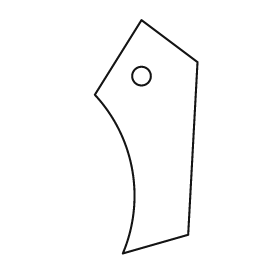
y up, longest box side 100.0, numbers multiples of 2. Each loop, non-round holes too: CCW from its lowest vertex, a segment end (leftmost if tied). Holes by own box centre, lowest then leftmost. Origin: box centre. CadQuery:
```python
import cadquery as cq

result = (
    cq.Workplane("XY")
    .moveTo(-10.0, -50.0)
    .lineTo(18.0, -42.0)
    .lineTo(22.0, 32.0)
    .lineTo(-2.0, 50.0)
    .lineTo(-22.0, 18.0)
    .threePointArc((-6.0, -14.0), (-10.0, -50.0))
    .close()
    .moveTo(-2.0, 26.0)
    .circle(4.0)
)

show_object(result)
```